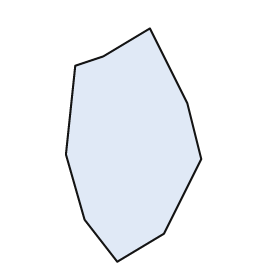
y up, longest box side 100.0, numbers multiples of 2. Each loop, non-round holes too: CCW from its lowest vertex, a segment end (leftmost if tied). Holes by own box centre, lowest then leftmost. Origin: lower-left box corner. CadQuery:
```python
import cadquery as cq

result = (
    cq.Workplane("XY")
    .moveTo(22.0, 0.0)
    .lineTo(42.0, 12.0)
    .lineTo(58.0, 44.0)
    .lineTo(52.0, 68.0)
    .lineTo(36.0, 100.0)
    .lineTo(16.0, 88.0)
    .lineTo(4.0, 84.0)
    .lineTo(0.0, 46.0)
    .lineTo(8.0, 18.0)
    .close()
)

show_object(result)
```